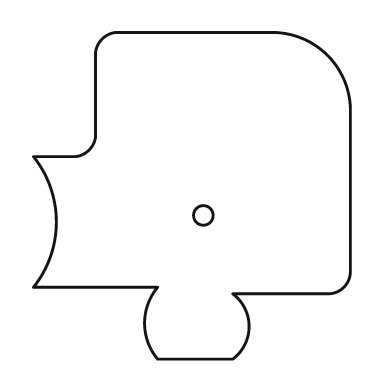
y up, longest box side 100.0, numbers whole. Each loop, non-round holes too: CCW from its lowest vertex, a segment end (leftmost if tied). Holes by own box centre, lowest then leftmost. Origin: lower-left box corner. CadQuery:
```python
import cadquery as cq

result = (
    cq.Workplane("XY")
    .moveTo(38.0, 0.0)
    .lineTo(61.0, 0.0)
    .threePointArc((66.0, 10.0), (61.0, 20.0))
    .lineTo(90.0, 20.0)
    .threePointArc((95.0, 22.0), (97.0, 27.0))
    .lineTo(97.0, 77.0)
    .threePointArc((90.0, 93.0), (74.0, 100.0))
    .lineTo(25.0, 100.0)
    .threePointArc((21.0, 98.0), (19.0, 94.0))
    .lineTo(19.0, 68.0)
    .threePointArc((17.0, 64.0), (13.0, 62.0))
    .lineTo(0.0, 62.0)
    .threePointArc((7.0, 42.0), (0.0, 22.0))
    .lineTo(38.0, 22.0)
    .threePointArc((34.0, 11.0), (38.0, 0.0))
    .close()
    .moveTo(52.0, 44.0)
    .circle(3.0)
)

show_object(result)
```